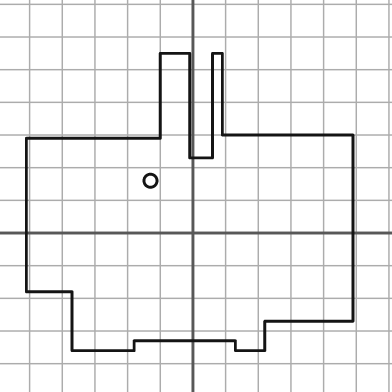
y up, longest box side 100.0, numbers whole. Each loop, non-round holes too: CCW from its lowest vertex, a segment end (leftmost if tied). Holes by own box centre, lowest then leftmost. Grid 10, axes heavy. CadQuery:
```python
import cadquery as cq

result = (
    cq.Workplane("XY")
    .moveTo(-37.0, -36.0)
    .lineTo(-18.0, -36.0)
    .lineTo(-18.0, -33.0)
    .lineTo(13.0, -33.0)
    .lineTo(13.0, -36.0)
    .lineTo(22.0, -36.0)
    .lineTo(22.0, -27.0)
    .lineTo(49.0, -27.0)
    .lineTo(49.0, 30.0)
    .lineTo(9.0, 30.0)
    .lineTo(9.0, 55.0)
    .lineTo(6.0, 55.0)
    .lineTo(6.0, 23.0)
    .lineTo(-1.0, 23.0)
    .lineTo(-1.0, 55.0)
    .lineTo(-10.0, 55.0)
    .lineTo(-10.0, 29.0)
    .lineTo(-51.0, 29.0)
    .lineTo(-51.0, -18.0)
    .lineTo(-37.0, -18.0)
    .close()
    .moveTo(-13.0, 16.0)
    .circle(2.0)
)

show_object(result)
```